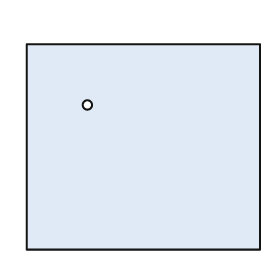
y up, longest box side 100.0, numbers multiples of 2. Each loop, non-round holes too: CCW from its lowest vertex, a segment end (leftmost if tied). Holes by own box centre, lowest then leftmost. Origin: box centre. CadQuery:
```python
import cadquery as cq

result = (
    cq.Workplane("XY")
    .moveTo(-50.0, -44.0)
    .lineTo(50.0, -44.0)
    .lineTo(50.0, 44.0)
    .lineTo(-50.0, 44.0)
    .close()
    .moveTo(-24.0, 18.0)
    .circle(2.0)
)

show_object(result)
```